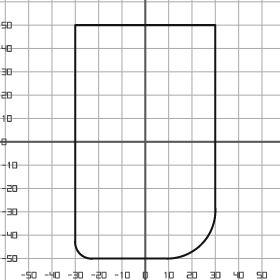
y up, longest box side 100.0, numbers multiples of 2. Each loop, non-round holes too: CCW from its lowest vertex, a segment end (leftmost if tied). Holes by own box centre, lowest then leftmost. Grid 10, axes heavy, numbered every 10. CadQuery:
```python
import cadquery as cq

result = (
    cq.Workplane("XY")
    .moveTo(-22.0, -50.0)
    .lineTo(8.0, -50.0)
    .threePointArc((24.0, -44.0), (30.0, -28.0))
    .lineTo(30.0, 50.0)
    .lineTo(-30.0, 50.0)
    .lineTo(-30.0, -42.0)
    .threePointArc((-28.0, -48.0), (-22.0, -50.0))
    .close()
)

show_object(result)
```